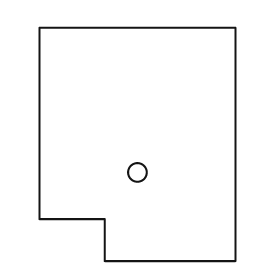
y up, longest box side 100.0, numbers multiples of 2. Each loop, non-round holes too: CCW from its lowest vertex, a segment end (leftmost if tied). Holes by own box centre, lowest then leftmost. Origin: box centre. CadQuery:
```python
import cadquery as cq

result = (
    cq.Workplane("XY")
    .moveTo(-14.0, -50.0)
    .lineTo(42.0, -50.0)
    .lineTo(42.0, 50.0)
    .lineTo(-42.0, 50.0)
    .lineTo(-42.0, -32.0)
    .lineTo(-14.0, -32.0)
    .close()
    .moveTo(0.0, -12.0)
    .circle(4.0)
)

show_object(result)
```